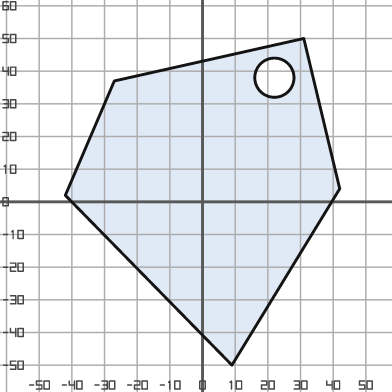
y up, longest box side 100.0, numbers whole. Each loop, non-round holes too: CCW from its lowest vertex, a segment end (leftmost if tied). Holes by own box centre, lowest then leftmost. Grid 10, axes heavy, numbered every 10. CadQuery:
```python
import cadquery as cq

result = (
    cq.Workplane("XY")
    .moveTo(9.0, -50.0)
    .lineTo(42.0, 4.0)
    .lineTo(31.0, 50.0)
    .lineTo(-27.0, 37.0)
    .lineTo(-42.0, 2.0)
    .close()
    .moveTo(22.0, 38.0)
    .circle(6.0)
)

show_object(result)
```